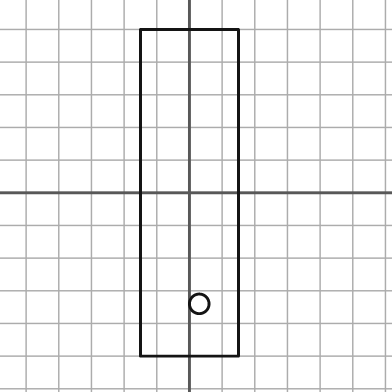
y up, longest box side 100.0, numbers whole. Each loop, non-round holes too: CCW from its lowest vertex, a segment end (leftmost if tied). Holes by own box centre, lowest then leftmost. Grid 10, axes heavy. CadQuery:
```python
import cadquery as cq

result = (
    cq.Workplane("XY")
    .moveTo(-15.0, -50.0)
    .lineTo(15.0, -50.0)
    .lineTo(15.0, 50.0)
    .lineTo(-15.0, 50.0)
    .close()
    .moveTo(3.0, -34.0)
    .circle(3.0)
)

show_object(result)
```